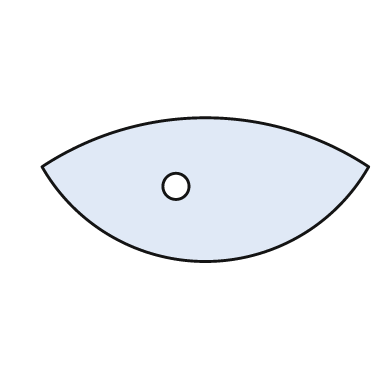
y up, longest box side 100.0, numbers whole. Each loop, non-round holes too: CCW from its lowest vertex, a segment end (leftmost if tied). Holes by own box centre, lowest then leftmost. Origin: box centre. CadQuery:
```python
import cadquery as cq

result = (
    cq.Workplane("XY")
    .moveTo(-50.0, 7.0)
    .threePointArc((0.0, -22.0), (50.0, 7.0))
    .threePointArc((0.0, 22.0), (-50.0, 7.0))
    .close()
    .moveTo(-9.0, 1.0)
    .circle(4.0)
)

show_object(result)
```